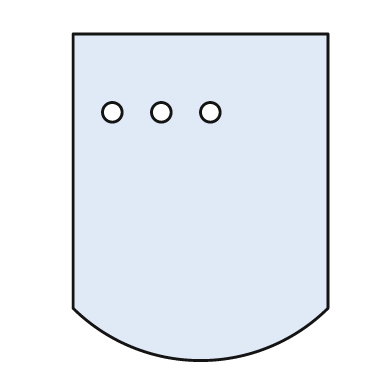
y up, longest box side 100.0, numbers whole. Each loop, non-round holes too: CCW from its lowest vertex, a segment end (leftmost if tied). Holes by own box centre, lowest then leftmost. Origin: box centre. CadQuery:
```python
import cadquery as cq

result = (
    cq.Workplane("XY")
    .moveTo(-39.0, -34.0)
    .threePointArc((0.0, -50.0), (39.0, -34.0))
    .lineTo(39.0, 50.0)
    .lineTo(-39.0, 50.0)
    .close()
    .moveTo(-27.0, 26.0)
    .circle(3.0)
    .moveTo(-12.0, 26.0)
    .circle(3.0)
    .moveTo(3.0, 26.0)
    .circle(3.0)
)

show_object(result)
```